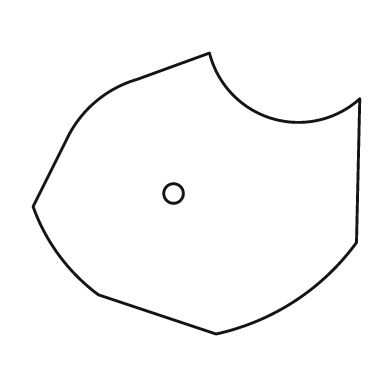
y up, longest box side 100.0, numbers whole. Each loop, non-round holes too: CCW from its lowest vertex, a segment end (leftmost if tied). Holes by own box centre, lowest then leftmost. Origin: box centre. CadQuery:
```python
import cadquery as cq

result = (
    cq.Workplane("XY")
    .moveTo(6.0, -43.0)
    .threePointArc((30.0, -33.0), (49.0, -15.0))
    .lineTo(50.0, 29.0)
    .threePointArc((23.0, 23.0), (4.0, 43.0))
    .lineTo(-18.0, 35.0)
    .threePointArc((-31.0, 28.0), (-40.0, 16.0))
    .lineTo(-50.0, -4.0)
    .threePointArc((-42.0, -19.0), (-30.0, -31.0))
    .close()
    .moveTo(-7.0, 0.0)
    .circle(3.0)
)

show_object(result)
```